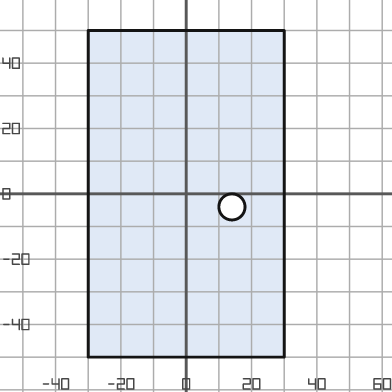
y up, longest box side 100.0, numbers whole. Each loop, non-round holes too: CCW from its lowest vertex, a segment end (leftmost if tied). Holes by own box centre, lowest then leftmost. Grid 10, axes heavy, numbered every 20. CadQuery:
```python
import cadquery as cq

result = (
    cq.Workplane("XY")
    .moveTo(-30.0, -50.0)
    .lineTo(30.0, -50.0)
    .lineTo(30.0, 50.0)
    .lineTo(-30.0, 50.0)
    .close()
    .moveTo(14.0, -4.0)
    .circle(4.0)
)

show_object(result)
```